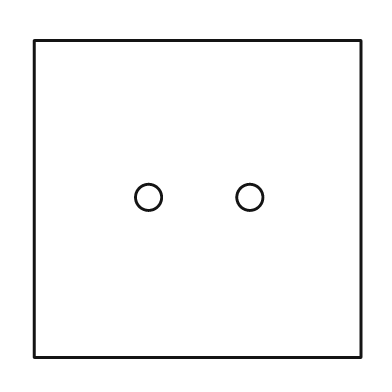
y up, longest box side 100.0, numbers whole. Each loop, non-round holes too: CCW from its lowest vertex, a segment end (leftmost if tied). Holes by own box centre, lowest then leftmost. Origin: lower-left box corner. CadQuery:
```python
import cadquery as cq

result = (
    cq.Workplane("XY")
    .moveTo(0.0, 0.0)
    .lineTo(100.0, 0.0)
    .lineTo(100.0, 97.0)
    .lineTo(0.0, 97.0)
    .close()
    .moveTo(35.0, 49.0)
    .circle(4.0)
    .moveTo(66.0, 49.0)
    .circle(4.0)
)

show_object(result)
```